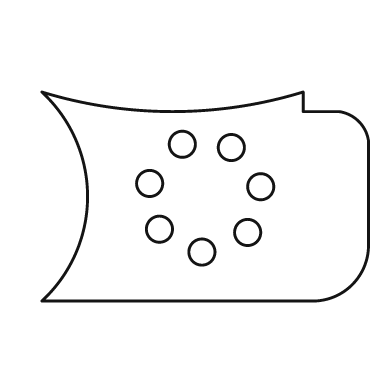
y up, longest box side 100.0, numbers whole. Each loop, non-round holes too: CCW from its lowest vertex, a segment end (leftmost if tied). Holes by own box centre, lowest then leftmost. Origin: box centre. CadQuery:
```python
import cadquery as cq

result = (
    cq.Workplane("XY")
    .moveTo(-50.0, -32.0)
    .lineTo(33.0, -32.0)
    .threePointArc((45.0, -27.0), (50.0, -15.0))
    .lineTo(50.0, 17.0)
    .threePointArc((47.0, 23.0), (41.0, 26.0))
    .lineTo(30.0, 26.0)
    .lineTo(30.0, 32.0)
    .threePointArc((-10.0, 26.0), (-50.0, 32.0))
    .threePointArc((-36.0, 0.0), (-50.0, -32.0))
    .close()
    .moveTo(-1.0, -17.0)
    .circle(4.0)
    .moveTo(13.0, -11.0)
    .circle(4.0)
    .moveTo(-14.0, -10.0)
    .circle(4.0)
    .moveTo(17.0, 3.0)
    .circle(4.0)
    .moveTo(-17.0, 4.0)
    .circle(4.0)
    .moveTo(8.0, 15.0)
    .circle(4.0)
    .moveTo(-7.0, 16.0)
    .circle(4.0)
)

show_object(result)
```